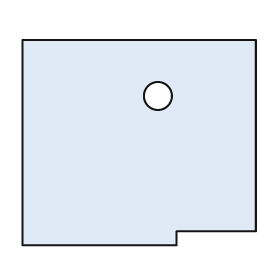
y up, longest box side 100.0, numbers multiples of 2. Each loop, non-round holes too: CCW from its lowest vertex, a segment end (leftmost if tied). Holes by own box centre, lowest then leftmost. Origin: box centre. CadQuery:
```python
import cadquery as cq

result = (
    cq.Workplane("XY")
    .moveTo(-50.0, -44.0)
    .lineTo(16.0, -44.0)
    .lineTo(16.0, -38.0)
    .lineTo(50.0, -38.0)
    .lineTo(50.0, 44.0)
    .lineTo(-50.0, 44.0)
    .close()
    .moveTo(8.0, 20.0)
    .circle(6.0)
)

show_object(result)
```